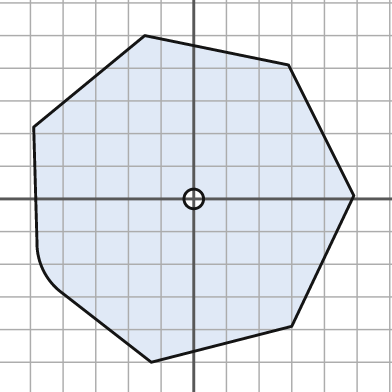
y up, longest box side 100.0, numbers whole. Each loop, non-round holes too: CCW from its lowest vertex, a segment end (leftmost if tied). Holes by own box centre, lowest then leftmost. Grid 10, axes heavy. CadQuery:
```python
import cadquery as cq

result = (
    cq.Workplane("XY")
    .moveTo(-13.0, -50.0)
    .lineTo(30.0, -39.0)
    .lineTo(49.0, 1.0)
    .lineTo(29.0, 41.0)
    .lineTo(-15.0, 50.0)
    .lineTo(-49.0, 22.0)
    .lineTo(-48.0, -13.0)
    .threePointArc((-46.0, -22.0), (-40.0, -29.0))
    .close()
    .moveTo(0.0, 0.0)
    .circle(3.0)
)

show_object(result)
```